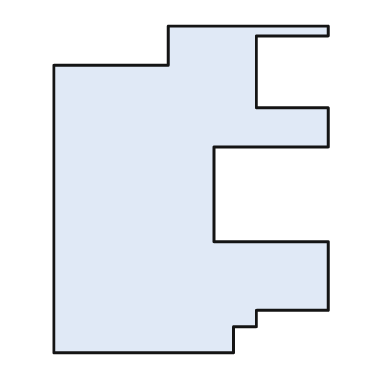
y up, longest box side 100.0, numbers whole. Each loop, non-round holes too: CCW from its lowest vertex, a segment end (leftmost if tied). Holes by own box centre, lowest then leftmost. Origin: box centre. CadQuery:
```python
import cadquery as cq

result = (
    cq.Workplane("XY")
    .moveTo(-42.0, -50.0)
    .lineTo(13.0, -50.0)
    .lineTo(13.0, -42.0)
    .lineTo(20.0, -42.0)
    .lineTo(20.0, -37.0)
    .lineTo(42.0, -37.0)
    .lineTo(42.0, -16.0)
    .lineTo(7.0, -16.0)
    .lineTo(7.0, 13.0)
    .lineTo(42.0, 13.0)
    .lineTo(42.0, 25.0)
    .lineTo(20.0, 25.0)
    .lineTo(20.0, 47.0)
    .lineTo(42.0, 47.0)
    .lineTo(42.0, 50.0)
    .lineTo(-7.0, 50.0)
    .lineTo(-7.0, 38.0)
    .lineTo(-42.0, 38.0)
    .close()
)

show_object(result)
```